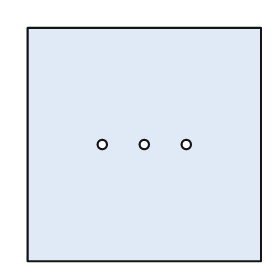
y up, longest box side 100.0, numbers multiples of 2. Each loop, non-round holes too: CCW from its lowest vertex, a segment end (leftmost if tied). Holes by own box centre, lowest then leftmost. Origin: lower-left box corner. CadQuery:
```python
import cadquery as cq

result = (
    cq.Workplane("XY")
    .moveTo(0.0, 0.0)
    .lineTo(100.0, 0.0)
    .lineTo(100.0, 100.0)
    .lineTo(0.0, 100.0)
    .close()
    .moveTo(32.0, 50.0)
    .circle(2.0)
    .moveTo(50.0, 50.0)
    .circle(2.0)
    .moveTo(68.0, 50.0)
    .circle(2.0)
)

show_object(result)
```